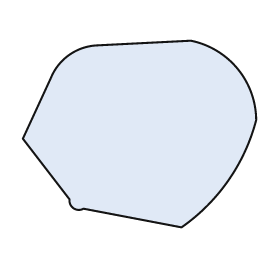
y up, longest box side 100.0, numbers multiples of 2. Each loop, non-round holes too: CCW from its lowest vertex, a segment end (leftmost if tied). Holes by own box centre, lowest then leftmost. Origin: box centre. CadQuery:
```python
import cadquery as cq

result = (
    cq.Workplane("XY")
    .moveTo(18.0, -40.0)
    .threePointArc((38.0, -20.0), (50.0, 6.0))
    .threePointArc((42.0, 28.0), (22.0, 40.0))
    .lineTo(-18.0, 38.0)
    .threePointArc((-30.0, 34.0), (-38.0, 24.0))
    .lineTo(-50.0, -2.0)
    .lineTo(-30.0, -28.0)
    .threePointArc((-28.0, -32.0), (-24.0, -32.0))
    .close()
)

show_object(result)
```